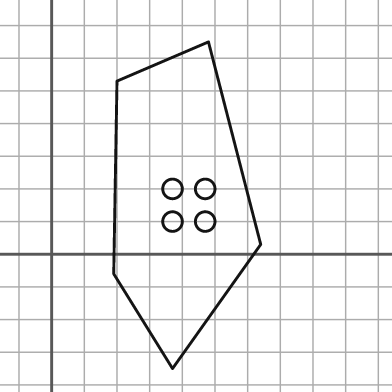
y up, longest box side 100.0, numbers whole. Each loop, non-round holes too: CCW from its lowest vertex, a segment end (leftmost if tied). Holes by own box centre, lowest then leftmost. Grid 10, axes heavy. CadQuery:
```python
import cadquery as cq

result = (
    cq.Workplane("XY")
    .moveTo(37.0, -35.0)
    .lineTo(64.0, 3.0)
    .lineTo(48.0, 65.0)
    .lineTo(20.0, 53.0)
    .lineTo(19.0, -6.0)
    .close()
    .moveTo(37.0, 10.0)
    .circle(3.0)
    .moveTo(47.0, 10.0)
    .circle(3.0)
    .moveTo(37.0, 20.0)
    .circle(3.0)
    .moveTo(47.0, 20.0)
    .circle(3.0)
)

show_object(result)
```